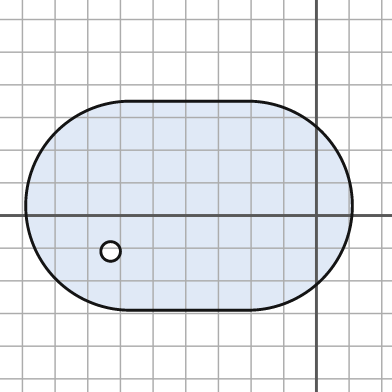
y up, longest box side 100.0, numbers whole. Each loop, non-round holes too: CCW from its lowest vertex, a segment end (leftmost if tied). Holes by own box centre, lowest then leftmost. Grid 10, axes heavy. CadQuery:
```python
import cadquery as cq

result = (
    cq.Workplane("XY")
    .moveTo(-57.0, -29.0)
    .lineTo(-21.0, -29.0)
    .threePointArc((11.0, 3.0), (-21.0, 35.0))
    .lineTo(-57.0, 35.0)
    .threePointArc((-89.0, 3.0), (-57.0, -29.0))
    .close()
    .moveTo(-63.0, -11.0)
    .circle(3.0)
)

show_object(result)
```